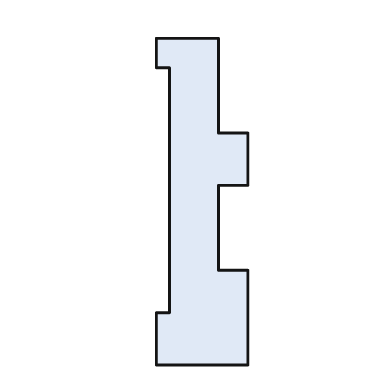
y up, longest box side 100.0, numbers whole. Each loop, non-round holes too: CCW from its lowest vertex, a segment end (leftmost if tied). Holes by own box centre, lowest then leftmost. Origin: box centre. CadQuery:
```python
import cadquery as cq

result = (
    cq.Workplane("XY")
    .moveTo(-14.0, -50.0)
    .lineTo(14.0, -50.0)
    .lineTo(14.0, -21.0)
    .lineTo(5.0, -21.0)
    .lineTo(5.0, 5.0)
    .lineTo(14.0, 5.0)
    .lineTo(14.0, 21.0)
    .lineTo(5.0, 21.0)
    .lineTo(5.0, 50.0)
    .lineTo(-14.0, 50.0)
    .lineTo(-14.0, 41.0)
    .lineTo(-10.0, 41.0)
    .lineTo(-10.0, -34.0)
    .lineTo(-14.0, -34.0)
    .close()
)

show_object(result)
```